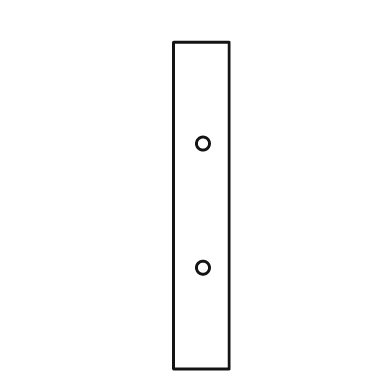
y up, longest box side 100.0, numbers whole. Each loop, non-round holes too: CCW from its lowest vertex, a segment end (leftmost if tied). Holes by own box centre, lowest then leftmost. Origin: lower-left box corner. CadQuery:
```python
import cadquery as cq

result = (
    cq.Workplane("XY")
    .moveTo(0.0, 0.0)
    .lineTo(17.0, 0.0)
    .lineTo(17.0, 100.0)
    .lineTo(0.0, 100.0)
    .close()
    .moveTo(9.0, 31.0)
    .circle(2.0)
    .moveTo(9.0, 69.0)
    .circle(2.0)
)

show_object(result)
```